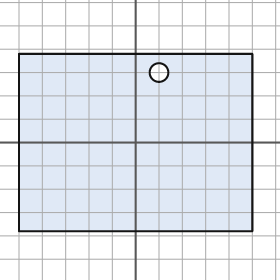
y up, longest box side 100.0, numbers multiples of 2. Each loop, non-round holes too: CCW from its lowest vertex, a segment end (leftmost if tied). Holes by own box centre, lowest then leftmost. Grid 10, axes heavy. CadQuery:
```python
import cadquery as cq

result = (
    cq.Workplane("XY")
    .moveTo(-50.0, -38.0)
    .lineTo(50.0, -38.0)
    .lineTo(50.0, 38.0)
    .lineTo(-50.0, 38.0)
    .close()
    .moveTo(10.0, 30.0)
    .circle(4.0)
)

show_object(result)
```